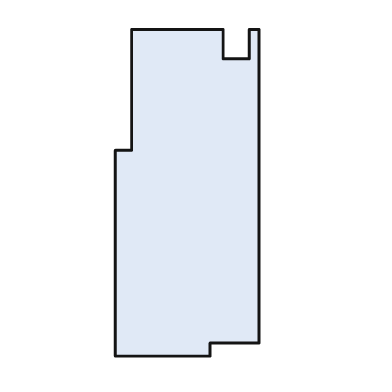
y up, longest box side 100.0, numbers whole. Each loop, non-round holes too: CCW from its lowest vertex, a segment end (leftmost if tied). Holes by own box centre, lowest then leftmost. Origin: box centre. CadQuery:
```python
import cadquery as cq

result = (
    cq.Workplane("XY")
    .moveTo(-22.0, -50.0)
    .lineTo(7.0, -50.0)
    .lineTo(7.0, -46.0)
    .lineTo(22.0, -46.0)
    .lineTo(22.0, 50.0)
    .lineTo(19.0, 50.0)
    .lineTo(19.0, 41.0)
    .lineTo(11.0, 41.0)
    .lineTo(11.0, 50.0)
    .lineTo(-17.0, 50.0)
    .lineTo(-17.0, 13.0)
    .lineTo(-22.0, 13.0)
    .close()
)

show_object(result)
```